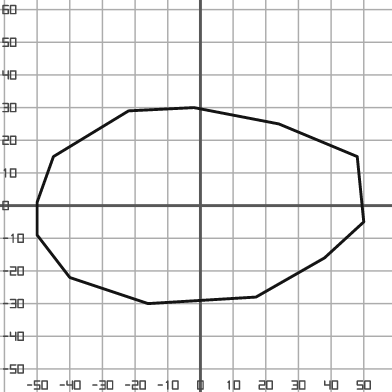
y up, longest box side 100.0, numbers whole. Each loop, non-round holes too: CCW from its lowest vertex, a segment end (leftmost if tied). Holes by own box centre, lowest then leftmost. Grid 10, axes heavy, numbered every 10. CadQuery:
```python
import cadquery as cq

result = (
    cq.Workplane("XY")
    .moveTo(-16.0, -30.0)
    .lineTo(17.0, -28.0)
    .lineTo(38.0, -16.0)
    .lineTo(50.0, -5.0)
    .lineTo(48.0, 15.0)
    .lineTo(24.0, 25.0)
    .lineTo(-2.0, 30.0)
    .lineTo(-22.0, 29.0)
    .lineTo(-45.0, 15.0)
    .lineTo(-50.0, 1.0)
    .lineTo(-50.0, -9.0)
    .lineTo(-40.0, -22.0)
    .close()
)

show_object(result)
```